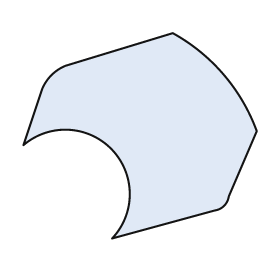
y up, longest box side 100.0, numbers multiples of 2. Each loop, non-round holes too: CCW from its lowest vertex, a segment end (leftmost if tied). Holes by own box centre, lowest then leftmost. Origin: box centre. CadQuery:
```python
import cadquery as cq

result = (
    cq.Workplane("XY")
    .moveTo(-12.0, -44.0)
    .lineTo(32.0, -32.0)
    .threePointArc((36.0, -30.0), (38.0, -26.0))
    .lineTo(50.0, 2.0)
    .threePointArc((36.0, 26.0), (14.0, 44.0))
    .lineTo(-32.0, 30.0)
    .threePointArc((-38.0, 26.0), (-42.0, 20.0))
    .lineTo(-50.0, -4.0)
    .threePointArc((-12.0, -6.0), (-12.0, -44.0))
    .close()
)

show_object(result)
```